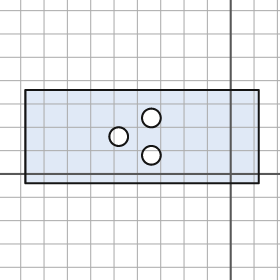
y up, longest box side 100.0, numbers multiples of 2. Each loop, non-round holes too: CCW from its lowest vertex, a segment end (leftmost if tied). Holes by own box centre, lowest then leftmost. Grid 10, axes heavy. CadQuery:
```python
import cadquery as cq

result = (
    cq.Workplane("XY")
    .moveTo(-88.0, -4.0)
    .lineTo(12.0, -4.0)
    .lineTo(12.0, 36.0)
    .lineTo(-88.0, 36.0)
    .close()
    .moveTo(-34.0, 8.0)
    .circle(4.0)
    .moveTo(-48.0, 16.0)
    .circle(4.0)
    .moveTo(-34.0, 24.0)
    .circle(4.0)
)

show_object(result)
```